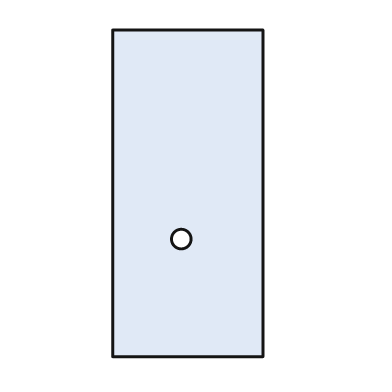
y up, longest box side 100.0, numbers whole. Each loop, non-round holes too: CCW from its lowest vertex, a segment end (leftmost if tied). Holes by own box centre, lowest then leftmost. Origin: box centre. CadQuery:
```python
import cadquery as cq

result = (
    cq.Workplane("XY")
    .moveTo(-23.0, -50.0)
    .lineTo(23.0, -50.0)
    .lineTo(23.0, 50.0)
    .lineTo(-23.0, 50.0)
    .close()
    .moveTo(-2.0, -14.0)
    .circle(3.0)
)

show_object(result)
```